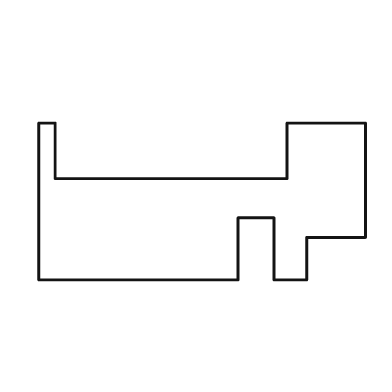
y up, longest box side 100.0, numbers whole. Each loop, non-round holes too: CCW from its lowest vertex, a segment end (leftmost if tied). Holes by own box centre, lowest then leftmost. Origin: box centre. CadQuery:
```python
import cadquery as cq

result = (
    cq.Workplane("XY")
    .moveTo(-50.0, -24.0)
    .lineTo(11.0, -24.0)
    .lineTo(11.0, -5.0)
    .lineTo(22.0, -5.0)
    .lineTo(22.0, -24.0)
    .lineTo(32.0, -24.0)
    .lineTo(32.0, -11.0)
    .lineTo(50.0, -11.0)
    .lineTo(50.0, 24.0)
    .lineTo(26.0, 24.0)
    .lineTo(26.0, 7.0)
    .lineTo(-45.0, 7.0)
    .lineTo(-45.0, 24.0)
    .lineTo(-50.0, 24.0)
    .close()
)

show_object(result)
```